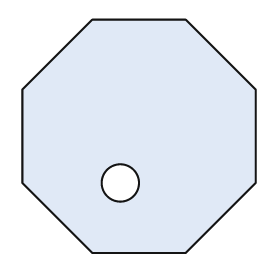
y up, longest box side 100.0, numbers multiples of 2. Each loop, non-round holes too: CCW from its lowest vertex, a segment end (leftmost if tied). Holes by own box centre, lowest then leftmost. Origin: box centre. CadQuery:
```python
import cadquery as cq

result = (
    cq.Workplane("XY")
    .moveTo(-20.0, -50.0)
    .lineTo(20.0, -50.0)
    .lineTo(50.0, -20.0)
    .lineTo(50.0, 20.0)
    .lineTo(20.0, 50.0)
    .lineTo(-20.0, 50.0)
    .lineTo(-50.0, 20.0)
    .lineTo(-50.0, -20.0)
    .close()
    .moveTo(-8.0, -20.0)
    .circle(8.0)
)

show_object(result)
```